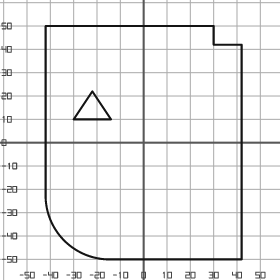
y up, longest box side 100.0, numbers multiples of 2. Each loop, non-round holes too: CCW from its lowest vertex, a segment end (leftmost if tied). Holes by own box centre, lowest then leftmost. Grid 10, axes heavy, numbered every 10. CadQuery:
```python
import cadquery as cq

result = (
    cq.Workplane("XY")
    .moveTo(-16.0, -50.0)
    .lineTo(42.0, -50.0)
    .lineTo(42.0, 42.0)
    .lineTo(30.0, 42.0)
    .lineTo(30.0, 50.0)
    .lineTo(-42.0, 50.0)
    .lineTo(-42.0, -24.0)
    .threePointArc((-34.0, -42.0), (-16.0, -50.0))
    .close()
    .moveTo(-30.0, 10.0)
    .lineTo(-14.0, 10.0)
    .lineTo(-22.0, 22.0)
    .close()
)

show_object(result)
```